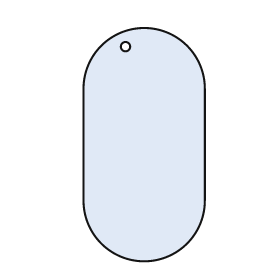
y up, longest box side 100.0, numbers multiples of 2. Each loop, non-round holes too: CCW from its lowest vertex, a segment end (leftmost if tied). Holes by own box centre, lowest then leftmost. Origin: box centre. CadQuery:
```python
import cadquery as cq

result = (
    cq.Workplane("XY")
    .moveTo(-26.0, -24.0)
    .threePointArc((0.0, -50.0), (26.0, -24.0))
    .lineTo(26.0, 24.0)
    .threePointArc((0.0, 50.0), (-26.0, 24.0))
    .close()
    .moveTo(-8.0, 42.0)
    .circle(2.0)
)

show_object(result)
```